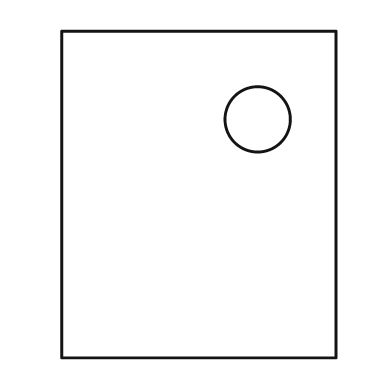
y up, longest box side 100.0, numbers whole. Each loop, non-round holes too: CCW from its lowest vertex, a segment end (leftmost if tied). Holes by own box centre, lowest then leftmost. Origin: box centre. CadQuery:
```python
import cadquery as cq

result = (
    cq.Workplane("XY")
    .moveTo(-42.0, -50.0)
    .lineTo(42.0, -50.0)
    .lineTo(42.0, 50.0)
    .lineTo(-42.0, 50.0)
    .close()
    .moveTo(18.0, 23.0)
    .circle(10.0)
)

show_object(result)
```